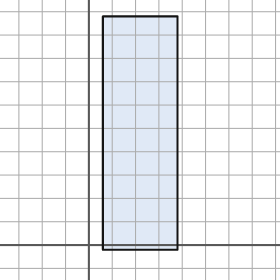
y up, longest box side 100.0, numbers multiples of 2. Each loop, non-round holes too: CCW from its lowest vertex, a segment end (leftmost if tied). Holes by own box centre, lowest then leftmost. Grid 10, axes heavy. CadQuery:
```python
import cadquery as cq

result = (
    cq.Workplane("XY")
    .moveTo(6.0, -2.0)
    .lineTo(38.0, -2.0)
    .lineTo(38.0, 98.0)
    .lineTo(6.0, 98.0)
    .close()
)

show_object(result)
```